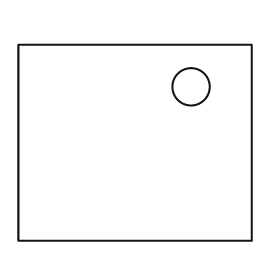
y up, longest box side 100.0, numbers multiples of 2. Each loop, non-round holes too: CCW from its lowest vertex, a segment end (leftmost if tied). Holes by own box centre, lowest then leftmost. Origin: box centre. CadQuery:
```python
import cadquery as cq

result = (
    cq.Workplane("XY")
    .moveTo(-50.0, -42.0)
    .lineTo(50.0, -42.0)
    .lineTo(50.0, 42.0)
    .lineTo(-50.0, 42.0)
    .close()
    .moveTo(24.0, 24.0)
    .circle(8.0)
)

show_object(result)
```